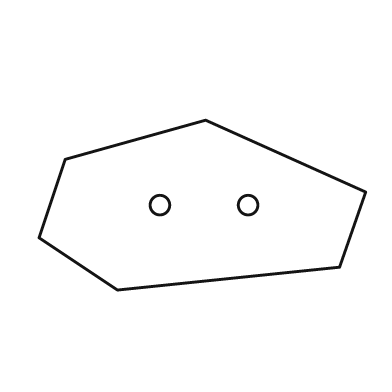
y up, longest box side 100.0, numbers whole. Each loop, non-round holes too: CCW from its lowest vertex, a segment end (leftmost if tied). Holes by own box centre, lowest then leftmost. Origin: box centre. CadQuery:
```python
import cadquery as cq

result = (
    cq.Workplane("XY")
    .moveTo(-26.0, -26.0)
    .lineTo(42.0, -19.0)
    .lineTo(50.0, 4.0)
    .lineTo(1.0, 26.0)
    .lineTo(-42.0, 14.0)
    .lineTo(-50.0, -10.0)
    .close()
    .moveTo(-13.0, 0.0)
    .circle(3.0)
    .moveTo(14.0, 0.0)
    .circle(3.0)
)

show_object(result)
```